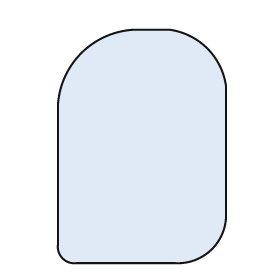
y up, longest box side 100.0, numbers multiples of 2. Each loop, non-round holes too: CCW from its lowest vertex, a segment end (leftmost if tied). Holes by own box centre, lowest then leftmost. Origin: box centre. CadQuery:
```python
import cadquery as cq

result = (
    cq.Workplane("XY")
    .moveTo(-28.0, -50.0)
    .lineTo(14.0, -50.0)
    .threePointArc((30.0, -44.0), (36.0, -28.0))
    .lineTo(36.0, 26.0)
    .threePointArc((28.0, 42.0), (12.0, 50.0))
    .lineTo(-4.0, 50.0)
    .threePointArc((-26.0, 40.0), (-36.0, 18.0))
    .lineTo(-36.0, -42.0)
    .threePointArc((-34.0, -48.0), (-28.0, -50.0))
    .close()
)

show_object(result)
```